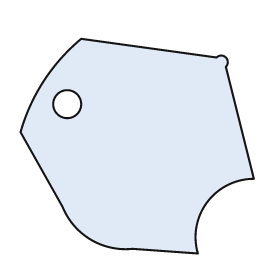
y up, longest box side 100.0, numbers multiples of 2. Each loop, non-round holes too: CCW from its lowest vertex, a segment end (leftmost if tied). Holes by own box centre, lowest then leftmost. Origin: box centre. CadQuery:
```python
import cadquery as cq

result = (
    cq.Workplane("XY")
    .moveTo(26.0, -46.0)
    .threePointArc((30.0, -24.0), (50.0, -14.0))
    .lineTo(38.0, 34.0)
    .threePointArc((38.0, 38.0), (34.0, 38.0))
    .lineTo(-24.0, 46.0)
    .threePointArc((-40.0, 28.0), (-50.0, 6.0))
    .lineTo(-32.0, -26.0)
    .threePointArc((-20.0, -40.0), (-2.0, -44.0))
    .close()
    .moveTo(-30.0, 18.0)
    .circle(6.0)
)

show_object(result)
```